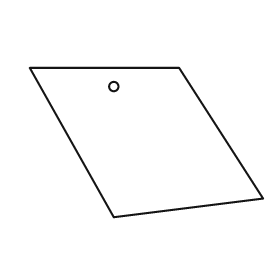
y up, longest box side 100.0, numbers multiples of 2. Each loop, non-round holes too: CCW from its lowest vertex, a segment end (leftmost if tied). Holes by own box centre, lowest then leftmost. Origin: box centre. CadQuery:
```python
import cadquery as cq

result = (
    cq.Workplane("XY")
    .moveTo(-14.0, -32.0)
    .lineTo(50.0, -24.0)
    .lineTo(14.0, 32.0)
    .lineTo(-50.0, 32.0)
    .close()
    .moveTo(-14.0, 24.0)
    .circle(2.0)
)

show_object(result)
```